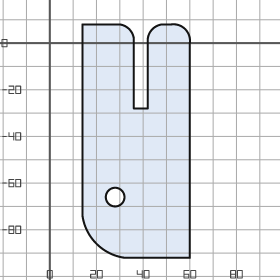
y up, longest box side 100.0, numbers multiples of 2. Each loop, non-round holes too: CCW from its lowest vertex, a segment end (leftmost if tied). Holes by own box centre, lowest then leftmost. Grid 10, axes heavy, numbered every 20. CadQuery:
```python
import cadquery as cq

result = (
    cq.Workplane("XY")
    .moveTo(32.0, -92.0)
    .lineTo(60.0, -92.0)
    .lineTo(60.0, 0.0)
    .threePointArc((58.0, 6.0), (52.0, 8.0))
    .lineTo(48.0, 8.0)
    .threePointArc((44.0, 6.0), (42.0, 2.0))
    .lineTo(42.0, -28.0)
    .lineTo(36.0, -28.0)
    .lineTo(36.0, 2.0)
    .threePointArc((34.0, 6.0), (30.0, 8.0))
    .lineTo(14.0, 8.0)
    .lineTo(14.0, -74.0)
    .threePointArc((20.0, -86.0), (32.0, -92.0))
    .close()
    .moveTo(28.0, -66.0)
    .circle(4.0)
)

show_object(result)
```